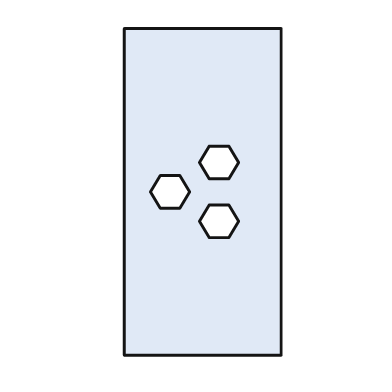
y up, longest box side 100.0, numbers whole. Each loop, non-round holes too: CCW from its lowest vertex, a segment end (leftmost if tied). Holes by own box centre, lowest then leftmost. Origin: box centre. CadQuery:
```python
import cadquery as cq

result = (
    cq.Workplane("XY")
    .moveTo(-24.0, -50.0)
    .lineTo(24.0, -50.0)
    .lineTo(24.0, 50.0)
    .lineTo(-24.0, 50.0)
    .close()
    .moveTo(2.0, -14.0)
    .lineTo(8.0, -14.0)
    .lineTo(11.0, -9.0)
    .lineTo(8.0, -4.0)
    .lineTo(2.0, -4.0)
    .lineTo(-1.0, -9.0)
    .close()
    .moveTo(-13.0, -5.0)
    .lineTo(-7.0, -5.0)
    .lineTo(-4.0, 0.0)
    .lineTo(-7.0, 5.0)
    .lineTo(-13.0, 5.0)
    .lineTo(-16.0, 0.0)
    .close()
    .moveTo(2.0, 4.0)
    .lineTo(8.0, 4.0)
    .lineTo(11.0, 9.0)
    .lineTo(8.0, 14.0)
    .lineTo(2.0, 14.0)
    .lineTo(-1.0, 9.0)
    .close()
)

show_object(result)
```